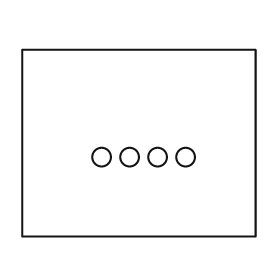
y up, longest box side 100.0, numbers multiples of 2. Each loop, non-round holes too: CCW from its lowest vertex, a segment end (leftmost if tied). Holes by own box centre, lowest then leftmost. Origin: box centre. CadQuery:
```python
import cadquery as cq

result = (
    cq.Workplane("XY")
    .moveTo(-50.0, -40.0)
    .lineTo(50.0, -40.0)
    .lineTo(50.0, 40.0)
    .lineTo(-50.0, 40.0)
    .close()
    .moveTo(-16.0, -6.0)
    .circle(4.0)
    .moveTo(-4.0, -6.0)
    .circle(4.0)
    .moveTo(8.0, -6.0)
    .circle(4.0)
    .moveTo(20.0, -6.0)
    .circle(4.0)
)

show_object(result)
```